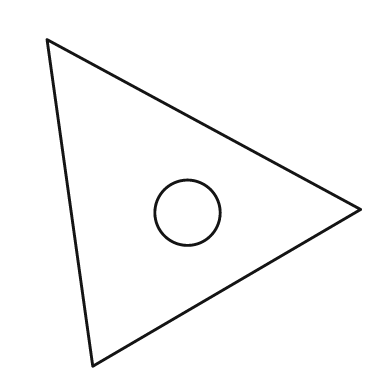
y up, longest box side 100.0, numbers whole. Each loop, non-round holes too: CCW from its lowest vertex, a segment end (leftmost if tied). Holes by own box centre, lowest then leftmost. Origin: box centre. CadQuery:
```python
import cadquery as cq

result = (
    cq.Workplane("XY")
    .moveTo(-34.0, -50.0)
    .lineTo(48.0, -2.0)
    .lineTo(-48.0, 50.0)
    .close()
    .moveTo(-5.0, -3.0)
    .circle(10.0)
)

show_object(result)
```